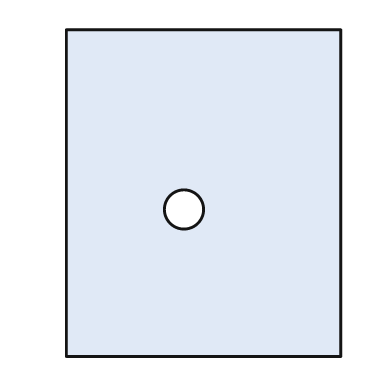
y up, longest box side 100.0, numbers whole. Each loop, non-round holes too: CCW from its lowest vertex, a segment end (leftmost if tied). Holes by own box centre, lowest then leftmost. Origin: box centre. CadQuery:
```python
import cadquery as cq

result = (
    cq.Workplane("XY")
    .moveTo(-42.0, -50.0)
    .lineTo(42.0, -50.0)
    .lineTo(42.0, 50.0)
    .lineTo(-42.0, 50.0)
    .close()
    .moveTo(-6.0, -5.0)
    .circle(6.0)
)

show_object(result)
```